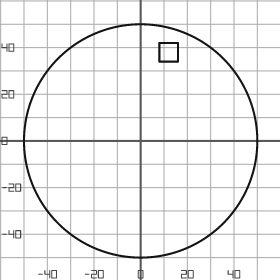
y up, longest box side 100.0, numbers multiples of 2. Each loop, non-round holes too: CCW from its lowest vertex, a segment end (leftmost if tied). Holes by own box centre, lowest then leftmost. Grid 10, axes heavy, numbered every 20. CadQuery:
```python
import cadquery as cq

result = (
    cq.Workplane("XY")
    .moveTo(0.0, 0.0)
    .circle(50.0)
    .moveTo(8.0, 34.0)
    .lineTo(16.0, 34.0)
    .lineTo(16.0, 42.0)
    .lineTo(8.0, 42.0)
    .close()
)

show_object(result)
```